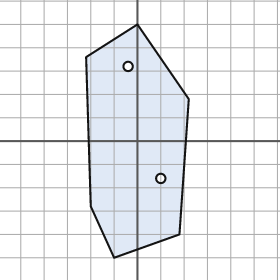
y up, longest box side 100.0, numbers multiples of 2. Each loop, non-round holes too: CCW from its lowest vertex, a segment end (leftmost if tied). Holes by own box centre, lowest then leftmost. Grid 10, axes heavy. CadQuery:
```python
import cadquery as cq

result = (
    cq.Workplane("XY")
    .moveTo(-10.0, -50.0)
    .lineTo(18.0, -40.0)
    .lineTo(22.0, 18.0)
    .lineTo(0.0, 50.0)
    .lineTo(-22.0, 36.0)
    .lineTo(-20.0, -28.0)
    .close()
    .moveTo(10.0, -16.0)
    .circle(2.0)
    .moveTo(-4.0, 32.0)
    .circle(2.0)
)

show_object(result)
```